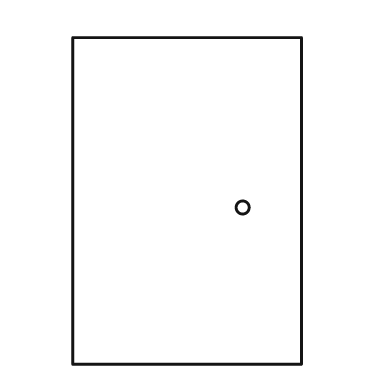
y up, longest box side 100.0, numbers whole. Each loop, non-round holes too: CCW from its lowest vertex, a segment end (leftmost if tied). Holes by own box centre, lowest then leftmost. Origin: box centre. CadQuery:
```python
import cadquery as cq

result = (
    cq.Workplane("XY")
    .moveTo(-35.0, -50.0)
    .lineTo(35.0, -50.0)
    .lineTo(35.0, 50.0)
    .lineTo(-35.0, 50.0)
    .close()
    .moveTo(17.0, -2.0)
    .circle(2.0)
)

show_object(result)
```